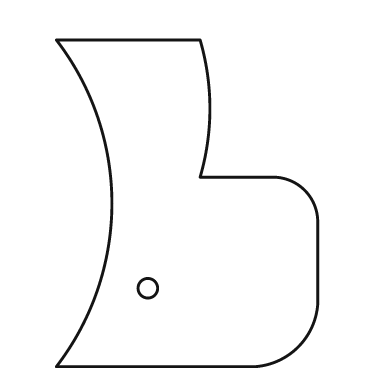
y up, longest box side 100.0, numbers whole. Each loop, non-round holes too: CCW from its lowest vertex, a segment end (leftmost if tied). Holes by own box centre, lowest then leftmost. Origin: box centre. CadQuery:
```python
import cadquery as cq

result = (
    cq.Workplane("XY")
    .moveTo(-40.0, -50.0)
    .lineTo(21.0, -50.0)
    .threePointArc((34.0, -44.0), (40.0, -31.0))
    .lineTo(40.0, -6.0)
    .threePointArc((36.0, 4.0), (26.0, 8.0))
    .lineTo(4.0, 8.0)
    .threePointArc((7.0, 29.0), (4.0, 50.0))
    .lineTo(-40.0, 50.0)
    .threePointArc((-23.0, 0.0), (-40.0, -50.0))
    .close()
    .moveTo(-12.0, -26.0)
    .circle(3.0)
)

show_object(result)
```